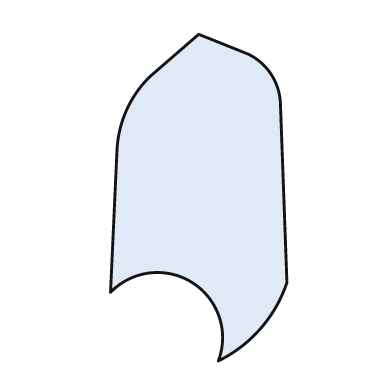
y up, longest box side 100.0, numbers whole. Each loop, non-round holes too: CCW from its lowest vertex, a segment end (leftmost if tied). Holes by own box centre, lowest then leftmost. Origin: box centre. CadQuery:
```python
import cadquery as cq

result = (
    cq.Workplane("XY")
    .moveTo(6.0, -50.0)
    .threePointArc((19.0, -40.0), (27.0, -26.0))
    .lineTo(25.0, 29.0)
    .threePointArc((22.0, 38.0), (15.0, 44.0))
    .lineTo(0.0, 50.0)
    .lineTo(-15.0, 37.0)
    .threePointArc((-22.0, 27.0), (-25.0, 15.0))
    .lineTo(-27.0, -29.0)
    .threePointArc((-2.0, -26.0), (6.0, -50.0))
    .close()
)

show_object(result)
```